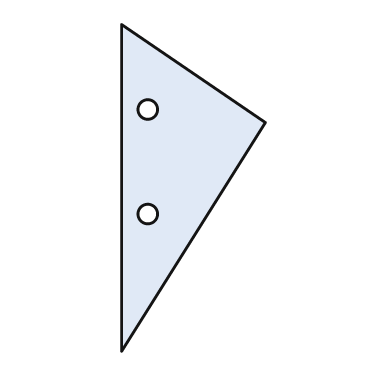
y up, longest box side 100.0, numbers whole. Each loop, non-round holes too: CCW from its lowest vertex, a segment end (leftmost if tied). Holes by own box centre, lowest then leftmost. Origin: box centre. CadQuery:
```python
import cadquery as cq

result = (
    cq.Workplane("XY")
    .moveTo(-22.0, -50.0)
    .lineTo(22.0, 20.0)
    .lineTo(-22.0, 50.0)
    .close()
    .moveTo(-14.0, -8.0)
    .circle(3.0)
    .moveTo(-14.0, 24.0)
    .circle(3.0)
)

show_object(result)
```